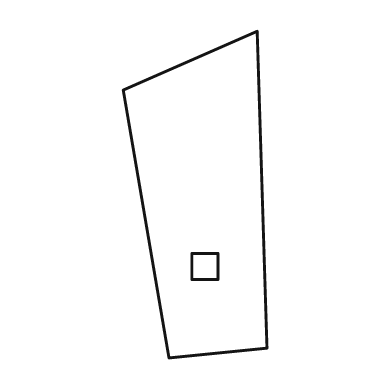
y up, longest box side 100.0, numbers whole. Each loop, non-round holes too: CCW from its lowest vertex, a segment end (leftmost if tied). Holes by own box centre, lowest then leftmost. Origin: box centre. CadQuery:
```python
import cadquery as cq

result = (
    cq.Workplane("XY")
    .moveTo(-8.0, -50.0)
    .lineTo(22.0, -47.0)
    .lineTo(19.0, 50.0)
    .lineTo(-22.0, 32.0)
    .close()
    .moveTo(-1.0, -26.0)
    .lineTo(7.0, -26.0)
    .lineTo(7.0, -18.0)
    .lineTo(-1.0, -18.0)
    .close()
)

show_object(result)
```